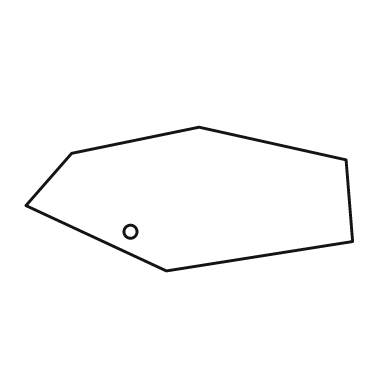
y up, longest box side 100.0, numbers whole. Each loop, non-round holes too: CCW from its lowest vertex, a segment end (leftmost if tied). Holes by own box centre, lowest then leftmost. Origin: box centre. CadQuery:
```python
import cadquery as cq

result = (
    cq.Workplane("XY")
    .moveTo(-7.0, -22.0)
    .lineTo(50.0, -13.0)
    .lineTo(48.0, 12.0)
    .lineTo(3.0, 22.0)
    .lineTo(-36.0, 14.0)
    .lineTo(-50.0, -2.0)
    .close()
    .moveTo(-18.0, -10.0)
    .circle(2.0)
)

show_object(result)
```